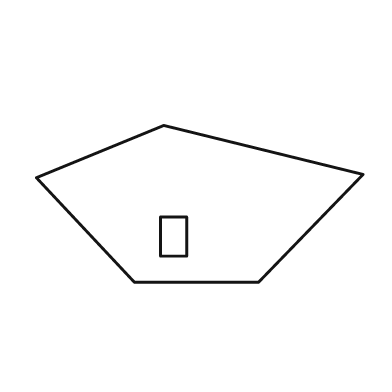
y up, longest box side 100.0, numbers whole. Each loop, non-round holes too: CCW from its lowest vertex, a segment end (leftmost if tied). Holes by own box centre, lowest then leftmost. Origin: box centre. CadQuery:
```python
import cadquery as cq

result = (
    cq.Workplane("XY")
    .moveTo(-20.0, -24.0)
    .lineTo(18.0, -24.0)
    .lineTo(50.0, 9.0)
    .lineTo(-11.0, 24.0)
    .lineTo(-50.0, 8.0)
    .close()
    .moveTo(-12.0, -16.0)
    .lineTo(-4.0, -16.0)
    .lineTo(-4.0, -4.0)
    .lineTo(-12.0, -4.0)
    .close()
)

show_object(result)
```